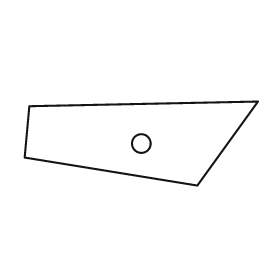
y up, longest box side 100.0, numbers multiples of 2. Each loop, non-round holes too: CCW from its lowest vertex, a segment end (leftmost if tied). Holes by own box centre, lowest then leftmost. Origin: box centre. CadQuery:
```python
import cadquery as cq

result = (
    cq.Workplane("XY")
    .moveTo(24.0, -18.0)
    .lineTo(50.0, 18.0)
    .lineTo(-48.0, 16.0)
    .lineTo(-50.0, -6.0)
    .close()
    .moveTo(0.0, 0.0)
    .circle(4.0)
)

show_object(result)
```